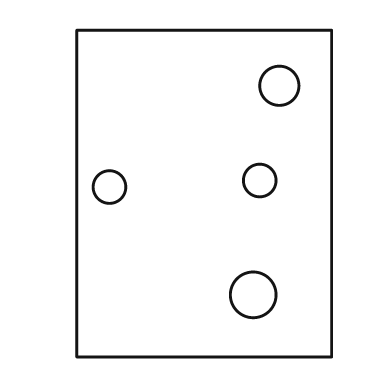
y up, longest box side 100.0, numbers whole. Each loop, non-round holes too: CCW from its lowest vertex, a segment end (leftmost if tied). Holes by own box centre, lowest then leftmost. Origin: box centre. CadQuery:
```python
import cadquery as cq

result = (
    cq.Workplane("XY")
    .moveTo(-39.0, -50.0)
    .lineTo(39.0, -50.0)
    .lineTo(39.0, 50.0)
    .lineTo(-39.0, 50.0)
    .close()
    .moveTo(15.0, -31.0)
    .circle(7.0)
    .moveTo(-29.0, 2.0)
    .circle(5.0)
    .moveTo(17.0, 4.0)
    .circle(5.0)
    .moveTo(23.0, 33.0)
    .circle(6.0)
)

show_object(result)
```